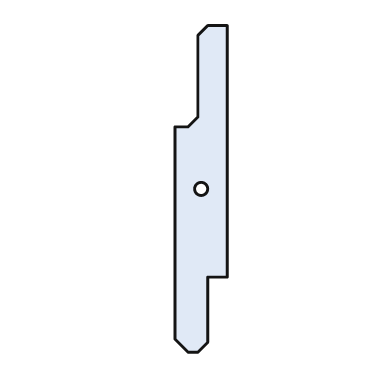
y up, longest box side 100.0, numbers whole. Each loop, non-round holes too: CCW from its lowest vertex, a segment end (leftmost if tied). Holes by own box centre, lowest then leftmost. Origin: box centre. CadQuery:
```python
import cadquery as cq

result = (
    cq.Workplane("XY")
    .moveTo(-4.0, -50.0)
    .lineTo(-1.0, -50.0)
    .lineTo(2.0, -47.0)
    .lineTo(2.0, -27.0)
    .lineTo(8.0, -27.0)
    .lineTo(8.0, 50.0)
    .lineTo(2.0, 50.0)
    .lineTo(-1.0, 47.0)
    .lineTo(-1.0, 22.0)
    .lineTo(-4.0, 19.0)
    .lineTo(-8.0, 19.0)
    .lineTo(-8.0, -46.0)
    .close()
    .moveTo(0.0, 0.0)
    .circle(2.0)
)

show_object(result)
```